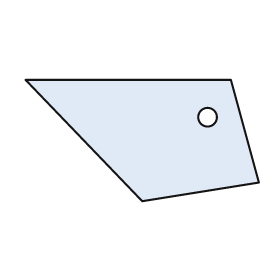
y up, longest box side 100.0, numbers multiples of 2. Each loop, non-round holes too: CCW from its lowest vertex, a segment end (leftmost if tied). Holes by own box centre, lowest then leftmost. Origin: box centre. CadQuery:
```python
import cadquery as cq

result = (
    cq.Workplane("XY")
    .moveTo(0.0, -26.0)
    .lineTo(50.0, -18.0)
    .lineTo(38.0, 26.0)
    .lineTo(-50.0, 26.0)
    .close()
    .moveTo(28.0, 10.0)
    .circle(4.0)
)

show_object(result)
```